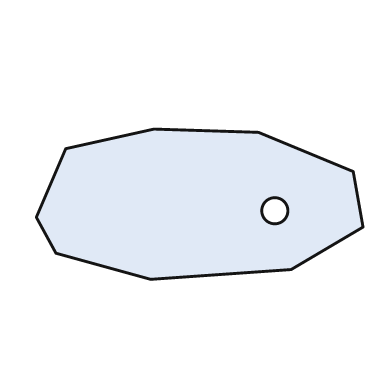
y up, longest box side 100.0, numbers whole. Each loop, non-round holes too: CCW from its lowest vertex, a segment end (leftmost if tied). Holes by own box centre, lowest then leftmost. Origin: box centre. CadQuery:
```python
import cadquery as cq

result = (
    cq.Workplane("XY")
    .moveTo(-15.0, -23.0)
    .lineTo(28.0, -20.0)
    .lineTo(50.0, -7.0)
    .lineTo(47.0, 10.0)
    .lineTo(18.0, 22.0)
    .lineTo(-14.0, 23.0)
    .lineTo(-41.0, 17.0)
    .lineTo(-50.0, -4.0)
    .lineTo(-44.0, -15.0)
    .close()
    .moveTo(23.0, -2.0)
    .circle(4.0)
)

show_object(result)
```